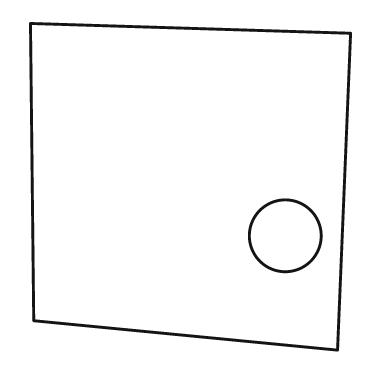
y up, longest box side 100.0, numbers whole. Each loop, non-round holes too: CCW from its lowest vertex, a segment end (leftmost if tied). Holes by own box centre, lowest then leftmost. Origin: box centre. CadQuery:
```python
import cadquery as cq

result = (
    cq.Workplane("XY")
    .moveTo(45.0, -50.0)
    .lineTo(49.0, 47.0)
    .lineTo(-49.0, 50.0)
    .lineTo(-48.0, -41.0)
    .close()
    .moveTo(29.0, -15.0)
    .circle(11.0)
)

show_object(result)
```